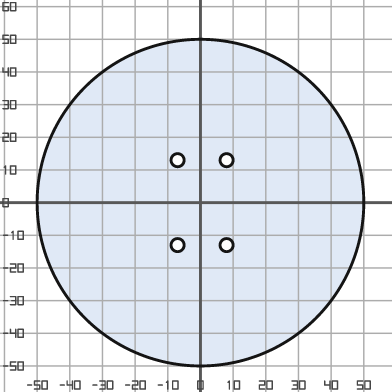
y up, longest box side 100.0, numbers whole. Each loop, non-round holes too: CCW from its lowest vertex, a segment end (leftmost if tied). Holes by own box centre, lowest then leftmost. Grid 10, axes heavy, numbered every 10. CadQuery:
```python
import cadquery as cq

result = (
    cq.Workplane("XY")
    .moveTo(0.0, 0.0)
    .circle(50.0)
    .moveTo(-7.0, -13.0)
    .circle(2.0)
    .moveTo(8.0, -13.0)
    .circle(2.0)
    .moveTo(-7.0, 13.0)
    .circle(2.0)
    .moveTo(8.0, 13.0)
    .circle(2.0)
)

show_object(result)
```